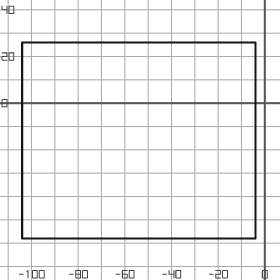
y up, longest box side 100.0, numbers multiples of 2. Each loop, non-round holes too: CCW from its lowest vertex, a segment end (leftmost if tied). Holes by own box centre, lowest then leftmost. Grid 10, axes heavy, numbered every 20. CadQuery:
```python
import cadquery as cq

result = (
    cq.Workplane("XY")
    .moveTo(-104.0, -58.0)
    .lineTo(-4.0, -58.0)
    .lineTo(-4.0, 26.0)
    .lineTo(-104.0, 26.0)
    .close()
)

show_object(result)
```